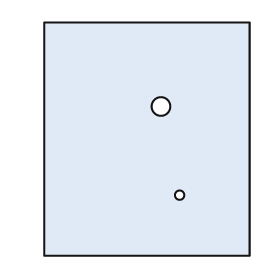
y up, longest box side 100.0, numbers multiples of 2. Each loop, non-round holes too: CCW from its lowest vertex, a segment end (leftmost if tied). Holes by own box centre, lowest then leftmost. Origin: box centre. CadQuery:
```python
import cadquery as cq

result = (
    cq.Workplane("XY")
    .moveTo(-44.0, -50.0)
    .lineTo(44.0, -50.0)
    .lineTo(44.0, 50.0)
    .lineTo(-44.0, 50.0)
    .close()
    .moveTo(14.0, -24.0)
    .circle(2.0)
    .moveTo(6.0, 14.0)
    .circle(4.0)
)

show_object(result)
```